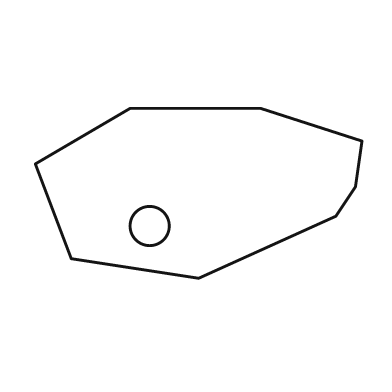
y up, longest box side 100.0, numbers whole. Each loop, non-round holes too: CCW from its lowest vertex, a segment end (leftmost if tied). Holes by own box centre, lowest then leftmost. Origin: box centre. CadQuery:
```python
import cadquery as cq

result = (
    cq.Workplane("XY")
    .moveTo(0.0, -26.0)
    .lineTo(42.0, -7.0)
    .lineTo(48.0, 2.0)
    .lineTo(50.0, 16.0)
    .lineTo(19.0, 26.0)
    .lineTo(-21.0, 26.0)
    .lineTo(-50.0, 9.0)
    .lineTo(-39.0, -20.0)
    .close()
    .moveTo(-15.0, -10.0)
    .circle(6.0)
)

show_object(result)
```